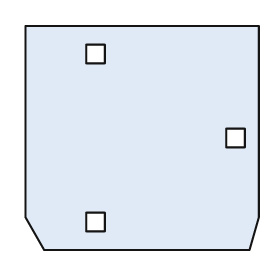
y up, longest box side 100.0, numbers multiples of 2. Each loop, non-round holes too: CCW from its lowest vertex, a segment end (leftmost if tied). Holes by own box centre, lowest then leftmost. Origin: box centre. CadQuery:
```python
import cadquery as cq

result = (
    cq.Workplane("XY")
    .moveTo(-42.0, -48.0)
    .lineTo(46.0, -48.0)
    .lineTo(50.0, -34.0)
    .lineTo(50.0, 48.0)
    .lineTo(-50.0, 48.0)
    .lineTo(-50.0, -34.0)
    .close()
    .moveTo(-24.0, -40.0)
    .lineTo(-16.0, -40.0)
    .lineTo(-16.0, -32.0)
    .lineTo(-24.0, -32.0)
    .close()
    .moveTo(36.0, -4.0)
    .lineTo(44.0, -4.0)
    .lineTo(44.0, 4.0)
    .lineTo(36.0, 4.0)
    .close()
    .moveTo(-24.0, 32.0)
    .lineTo(-16.0, 32.0)
    .lineTo(-16.0, 40.0)
    .lineTo(-24.0, 40.0)
    .close()
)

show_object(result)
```